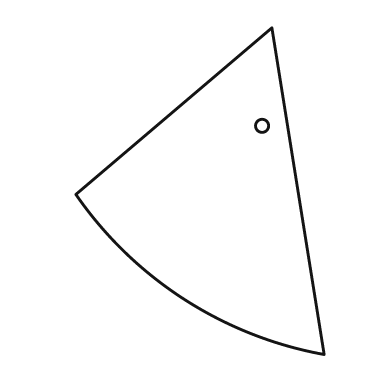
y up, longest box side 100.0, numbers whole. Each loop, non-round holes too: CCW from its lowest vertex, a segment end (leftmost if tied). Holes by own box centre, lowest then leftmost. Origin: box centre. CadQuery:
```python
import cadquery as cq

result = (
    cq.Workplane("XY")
    .moveTo(38.0, -50.0)
    .lineTo(22.0, 50.0)
    .lineTo(-38.0, -1.0)
    .threePointArc((-5.0, -33.0), (38.0, -50.0))
    .close()
    .moveTo(19.0, 20.0)
    .circle(2.0)
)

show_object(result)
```